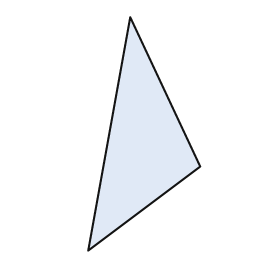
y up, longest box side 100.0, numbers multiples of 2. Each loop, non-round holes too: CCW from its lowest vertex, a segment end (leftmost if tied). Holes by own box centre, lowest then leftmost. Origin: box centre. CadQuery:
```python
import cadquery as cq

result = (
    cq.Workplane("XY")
    .moveTo(-24.0, -50.0)
    .lineTo(24.0, -14.0)
    .lineTo(-6.0, 50.0)
    .close()
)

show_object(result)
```